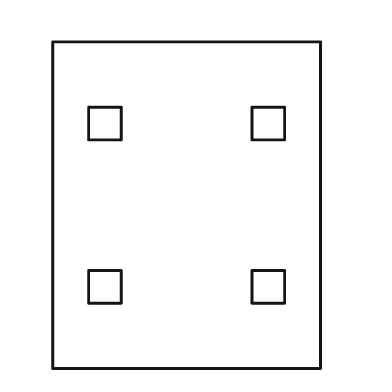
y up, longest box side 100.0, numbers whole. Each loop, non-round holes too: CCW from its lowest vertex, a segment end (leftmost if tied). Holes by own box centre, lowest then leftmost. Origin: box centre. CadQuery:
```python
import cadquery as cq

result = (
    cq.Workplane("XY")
    .moveTo(-41.0, -50.0)
    .lineTo(41.0, -50.0)
    .lineTo(41.0, 50.0)
    .lineTo(-41.0, 50.0)
    .close()
    .moveTo(-30.0, -30.0)
    .lineTo(-20.0, -30.0)
    .lineTo(-20.0, -20.0)
    .lineTo(-30.0, -20.0)
    .close()
    .moveTo(20.0, -30.0)
    .lineTo(30.0, -30.0)
    .lineTo(30.0, -20.0)
    .lineTo(20.0, -20.0)
    .close()
    .moveTo(-30.0, 20.0)
    .lineTo(-20.0, 20.0)
    .lineTo(-20.0, 30.0)
    .lineTo(-30.0, 30.0)
    .close()
    .moveTo(20.0, 20.0)
    .lineTo(30.0, 20.0)
    .lineTo(30.0, 30.0)
    .lineTo(20.0, 30.0)
    .close()
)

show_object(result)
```